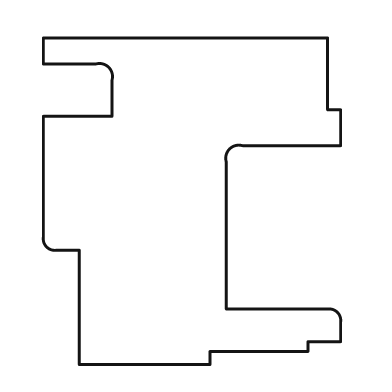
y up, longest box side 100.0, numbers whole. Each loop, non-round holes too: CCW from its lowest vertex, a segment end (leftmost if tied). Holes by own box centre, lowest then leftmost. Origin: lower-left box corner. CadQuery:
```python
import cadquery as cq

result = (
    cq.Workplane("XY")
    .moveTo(11.0, 0.0)
    .lineTo(51.0, 0.0)
    .lineTo(51.0, 4.0)
    .lineTo(81.0, 4.0)
    .lineTo(81.0, 7.0)
    .lineTo(91.0, 7.0)
    .lineTo(91.0, 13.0)
    .threePointArc((90.0, 16.0), (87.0, 17.0))
    .lineTo(56.0, 17.0)
    .lineTo(56.0, 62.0)
    .threePointArc((57.0, 66.0), (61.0, 67.0))
    .lineTo(91.0, 67.0)
    .lineTo(91.0, 78.0)
    .lineTo(87.0, 78.0)
    .lineTo(87.0, 100.0)
    .lineTo(0.0, 100.0)
    .lineTo(0.0, 92.0)
    .lineTo(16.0, 92.0)
    .threePointArc((20.0, 91.0), (21.0, 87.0))
    .lineTo(21.0, 76.0)
    .lineTo(0.0, 76.0)
    .lineTo(0.0, 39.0)
    .threePointArc((1.0, 36.0), (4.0, 35.0))
    .lineTo(11.0, 35.0)
    .close()
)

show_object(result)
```